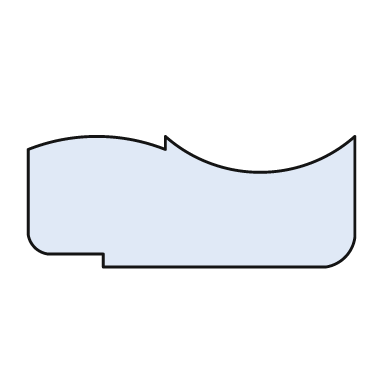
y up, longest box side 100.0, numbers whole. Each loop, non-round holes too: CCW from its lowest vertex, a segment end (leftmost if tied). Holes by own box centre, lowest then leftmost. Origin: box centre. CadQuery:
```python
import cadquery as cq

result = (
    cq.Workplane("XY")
    .moveTo(-27.0, -20.0)
    .lineTo(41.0, -20.0)
    .threePointArc((47.0, -17.0), (50.0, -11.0))
    .lineTo(50.0, 20.0)
    .threePointArc((21.0, 9.0), (-8.0, 20.0))
    .lineTo(-8.0, 16.0)
    .threePointArc((-29.0, 20.0), (-50.0, 16.0))
    .lineTo(-50.0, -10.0)
    .threePointArc((-48.0, -14.0), (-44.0, -16.0))
    .lineTo(-27.0, -16.0)
    .close()
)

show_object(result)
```